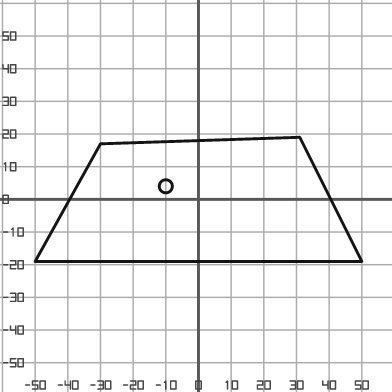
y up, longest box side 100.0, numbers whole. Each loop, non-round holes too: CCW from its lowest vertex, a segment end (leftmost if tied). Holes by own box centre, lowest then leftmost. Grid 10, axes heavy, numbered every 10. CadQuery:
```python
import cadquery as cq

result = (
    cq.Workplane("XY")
    .moveTo(-50.0, -19.0)
    .lineTo(50.0, -19.0)
    .lineTo(31.0, 19.0)
    .lineTo(-30.0, 17.0)
    .close()
    .moveTo(-10.0, 4.0)
    .circle(2.0)
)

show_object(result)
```